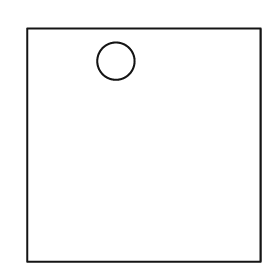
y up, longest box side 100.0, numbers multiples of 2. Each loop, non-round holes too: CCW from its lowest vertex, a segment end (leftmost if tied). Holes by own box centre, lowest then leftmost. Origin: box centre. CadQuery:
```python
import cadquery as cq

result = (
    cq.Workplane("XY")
    .moveTo(-50.0, -50.0)
    .lineTo(50.0, -50.0)
    .lineTo(50.0, 50.0)
    .lineTo(-50.0, 50.0)
    .close()
    .moveTo(-12.0, 36.0)
    .circle(8.0)
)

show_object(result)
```